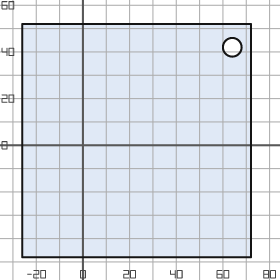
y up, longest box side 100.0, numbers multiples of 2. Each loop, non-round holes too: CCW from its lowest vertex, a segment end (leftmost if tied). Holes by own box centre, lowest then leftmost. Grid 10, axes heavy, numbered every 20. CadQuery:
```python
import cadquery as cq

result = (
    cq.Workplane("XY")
    .moveTo(-26.0, -48.0)
    .lineTo(72.0, -48.0)
    .lineTo(72.0, 52.0)
    .lineTo(-26.0, 52.0)
    .close()
    .moveTo(64.0, 42.0)
    .circle(4.0)
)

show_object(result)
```